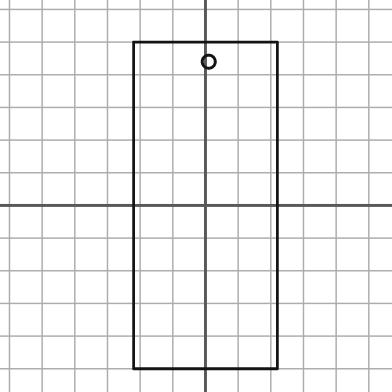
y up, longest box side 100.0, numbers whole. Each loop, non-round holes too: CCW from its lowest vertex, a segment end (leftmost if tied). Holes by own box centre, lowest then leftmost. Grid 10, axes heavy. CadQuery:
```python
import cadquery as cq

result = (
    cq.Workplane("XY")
    .moveTo(-22.0, -50.0)
    .lineTo(22.0, -50.0)
    .lineTo(22.0, 50.0)
    .lineTo(-22.0, 50.0)
    .close()
    .moveTo(1.0, 44.0)
    .circle(2.0)
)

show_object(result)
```